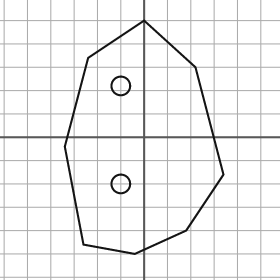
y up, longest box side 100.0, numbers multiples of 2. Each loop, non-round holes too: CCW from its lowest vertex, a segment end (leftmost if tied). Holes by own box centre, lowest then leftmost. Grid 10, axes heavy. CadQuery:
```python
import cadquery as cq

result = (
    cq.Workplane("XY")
    .moveTo(-4.0, -50.0)
    .lineTo(18.0, -40.0)
    .lineTo(34.0, -16.0)
    .lineTo(22.0, 30.0)
    .lineTo(0.0, 50.0)
    .lineTo(-24.0, 34.0)
    .lineTo(-34.0, -4.0)
    .lineTo(-26.0, -46.0)
    .close()
    .moveTo(-10.0, -20.0)
    .circle(4.0)
    .moveTo(-10.0, 22.0)
    .circle(4.0)
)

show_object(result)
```